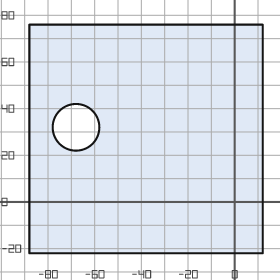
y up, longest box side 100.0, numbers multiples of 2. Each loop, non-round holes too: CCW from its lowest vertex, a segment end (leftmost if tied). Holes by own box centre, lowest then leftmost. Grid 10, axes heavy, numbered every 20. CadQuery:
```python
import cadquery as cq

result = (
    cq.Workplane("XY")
    .moveTo(-88.0, -22.0)
    .lineTo(12.0, -22.0)
    .lineTo(12.0, 76.0)
    .lineTo(-88.0, 76.0)
    .close()
    .moveTo(-68.0, 32.0)
    .circle(10.0)
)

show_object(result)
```